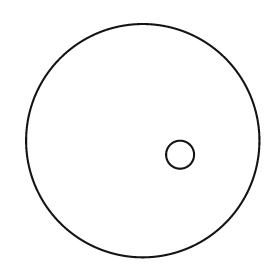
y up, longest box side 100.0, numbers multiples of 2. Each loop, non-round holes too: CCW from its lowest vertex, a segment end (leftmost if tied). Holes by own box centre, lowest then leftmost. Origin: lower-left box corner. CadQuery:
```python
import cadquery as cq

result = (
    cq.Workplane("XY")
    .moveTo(50.0, 50.0)
    .circle(50.0)
    .moveTo(66.0, 44.0)
    .circle(6.0)
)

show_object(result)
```